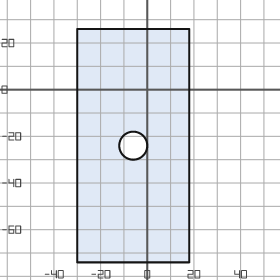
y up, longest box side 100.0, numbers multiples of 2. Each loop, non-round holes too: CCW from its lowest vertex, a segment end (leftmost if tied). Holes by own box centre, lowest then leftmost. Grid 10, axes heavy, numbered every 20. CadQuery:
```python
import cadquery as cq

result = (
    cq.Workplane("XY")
    .moveTo(-30.0, -74.0)
    .lineTo(18.0, -74.0)
    .lineTo(18.0, 26.0)
    .lineTo(-30.0, 26.0)
    .close()
    .moveTo(-6.0, -24.0)
    .circle(6.0)
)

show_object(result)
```